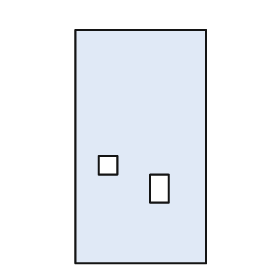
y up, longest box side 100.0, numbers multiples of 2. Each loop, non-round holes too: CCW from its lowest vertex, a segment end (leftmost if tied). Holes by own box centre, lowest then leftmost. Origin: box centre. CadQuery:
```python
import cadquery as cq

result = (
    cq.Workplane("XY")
    .moveTo(-28.0, -50.0)
    .lineTo(28.0, -50.0)
    .lineTo(28.0, 50.0)
    .lineTo(-28.0, 50.0)
    .close()
    .moveTo(4.0, -24.0)
    .lineTo(12.0, -24.0)
    .lineTo(12.0, -12.0)
    .lineTo(4.0, -12.0)
    .close()
    .moveTo(-18.0, -12.0)
    .lineTo(-10.0, -12.0)
    .lineTo(-10.0, -4.0)
    .lineTo(-18.0, -4.0)
    .close()
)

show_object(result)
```